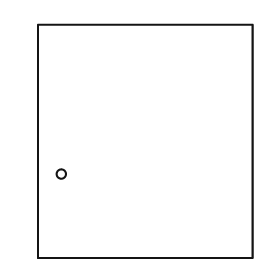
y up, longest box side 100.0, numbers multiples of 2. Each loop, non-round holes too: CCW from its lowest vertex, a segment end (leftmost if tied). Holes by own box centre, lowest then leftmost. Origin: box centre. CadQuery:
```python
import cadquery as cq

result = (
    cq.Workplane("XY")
    .moveTo(-46.0, -50.0)
    .lineTo(46.0, -50.0)
    .lineTo(46.0, 50.0)
    .lineTo(-46.0, 50.0)
    .close()
    .moveTo(-36.0, -14.0)
    .circle(2.0)
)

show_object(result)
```